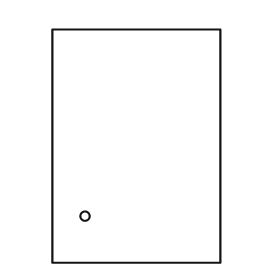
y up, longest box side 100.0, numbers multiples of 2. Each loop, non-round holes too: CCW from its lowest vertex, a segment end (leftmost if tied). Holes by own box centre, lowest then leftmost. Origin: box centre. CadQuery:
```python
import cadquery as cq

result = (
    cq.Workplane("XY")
    .moveTo(-36.0, -50.0)
    .lineTo(36.0, -50.0)
    .lineTo(36.0, 50.0)
    .lineTo(-36.0, 50.0)
    .close()
    .moveTo(-22.0, -30.0)
    .circle(2.0)
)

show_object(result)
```